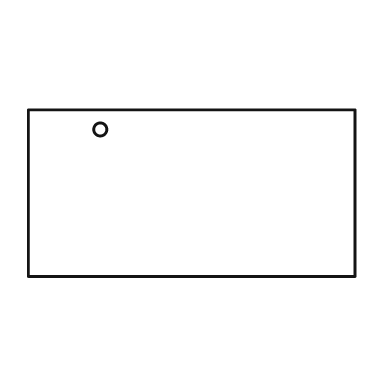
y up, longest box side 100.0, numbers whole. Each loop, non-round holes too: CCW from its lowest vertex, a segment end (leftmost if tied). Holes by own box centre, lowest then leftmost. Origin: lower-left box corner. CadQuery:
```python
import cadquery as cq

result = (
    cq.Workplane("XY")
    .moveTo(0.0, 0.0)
    .lineTo(100.0, 0.0)
    .lineTo(100.0, 51.0)
    .lineTo(0.0, 51.0)
    .close()
    .moveTo(22.0, 45.0)
    .circle(2.0)
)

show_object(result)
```